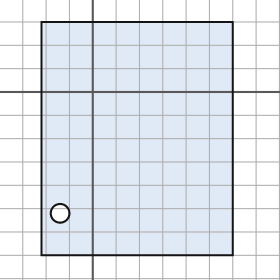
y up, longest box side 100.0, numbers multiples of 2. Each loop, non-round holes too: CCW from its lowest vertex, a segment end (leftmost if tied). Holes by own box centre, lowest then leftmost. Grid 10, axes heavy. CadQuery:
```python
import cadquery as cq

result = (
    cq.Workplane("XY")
    .moveTo(-22.0, -70.0)
    .lineTo(60.0, -70.0)
    .lineTo(60.0, 30.0)
    .lineTo(-22.0, 30.0)
    .close()
    .moveTo(-14.0, -52.0)
    .circle(4.0)
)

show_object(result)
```